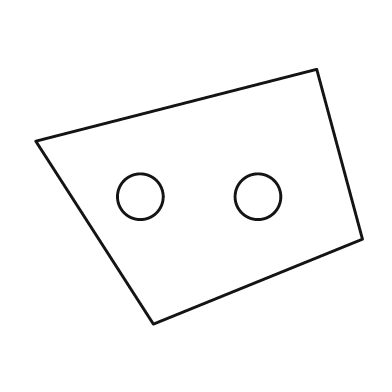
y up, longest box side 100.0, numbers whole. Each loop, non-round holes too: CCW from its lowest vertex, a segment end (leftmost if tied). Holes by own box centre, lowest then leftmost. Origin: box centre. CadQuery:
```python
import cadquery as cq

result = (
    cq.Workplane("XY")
    .moveTo(-14.0, -39.0)
    .lineTo(50.0, -13.0)
    .lineTo(36.0, 39.0)
    .lineTo(-50.0, 17.0)
    .close()
    .moveTo(-18.0, 0.0)
    .circle(7.0)
    .moveTo(18.0, 0.0)
    .circle(7.0)
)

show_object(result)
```